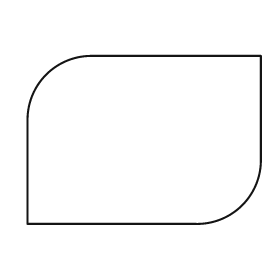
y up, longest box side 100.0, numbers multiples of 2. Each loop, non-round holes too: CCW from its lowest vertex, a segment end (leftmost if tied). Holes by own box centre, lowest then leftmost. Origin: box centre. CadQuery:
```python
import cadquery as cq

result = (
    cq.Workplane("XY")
    .moveTo(-50.0, -36.0)
    .lineTo(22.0, -36.0)
    .threePointArc((42.0, -28.0), (50.0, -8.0))
    .lineTo(50.0, 36.0)
    .lineTo(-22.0, 36.0)
    .threePointArc((-42.0, 28.0), (-50.0, 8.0))
    .close()
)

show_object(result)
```